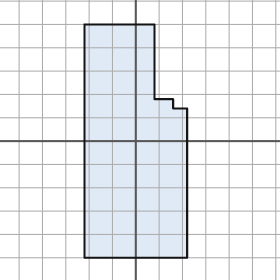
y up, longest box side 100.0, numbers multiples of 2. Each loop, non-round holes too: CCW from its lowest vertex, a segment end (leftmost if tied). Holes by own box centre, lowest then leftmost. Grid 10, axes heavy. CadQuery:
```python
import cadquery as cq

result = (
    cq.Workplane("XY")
    .moveTo(-22.0, -50.0)
    .lineTo(22.0, -50.0)
    .lineTo(22.0, 14.0)
    .lineTo(16.0, 14.0)
    .lineTo(16.0, 18.0)
    .lineTo(8.0, 18.0)
    .lineTo(8.0, 50.0)
    .lineTo(-22.0, 50.0)
    .close()
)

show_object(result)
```